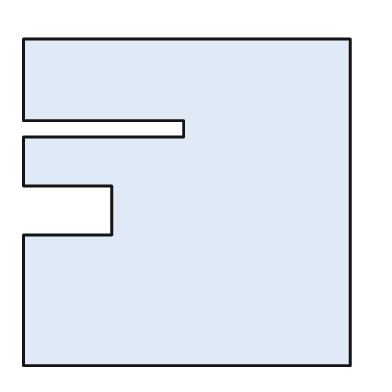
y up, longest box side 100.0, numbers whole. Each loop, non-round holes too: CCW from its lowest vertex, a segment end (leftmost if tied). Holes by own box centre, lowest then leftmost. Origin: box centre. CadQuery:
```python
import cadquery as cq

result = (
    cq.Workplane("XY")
    .moveTo(-50.0, -50.0)
    .lineTo(50.0, -50.0)
    .lineTo(50.0, 50.0)
    .lineTo(-50.0, 50.0)
    .lineTo(-50.0, 25.0)
    .lineTo(-1.0, 25.0)
    .lineTo(-1.0, 20.0)
    .lineTo(-50.0, 20.0)
    .lineTo(-50.0, 5.0)
    .lineTo(-23.0, 5.0)
    .lineTo(-23.0, -10.0)
    .lineTo(-50.0, -10.0)
    .close()
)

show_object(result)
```